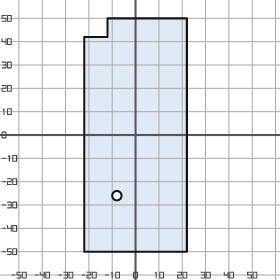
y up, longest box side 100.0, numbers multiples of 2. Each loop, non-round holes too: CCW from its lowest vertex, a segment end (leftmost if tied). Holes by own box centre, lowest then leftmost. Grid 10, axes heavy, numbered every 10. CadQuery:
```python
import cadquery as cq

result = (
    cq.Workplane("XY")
    .moveTo(-22.0, -50.0)
    .lineTo(22.0, -50.0)
    .lineTo(22.0, 50.0)
    .lineTo(-12.0, 50.0)
    .lineTo(-12.0, 42.0)
    .lineTo(-22.0, 42.0)
    .close()
    .moveTo(-8.0, -26.0)
    .circle(2.0)
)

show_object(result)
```